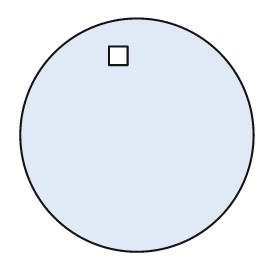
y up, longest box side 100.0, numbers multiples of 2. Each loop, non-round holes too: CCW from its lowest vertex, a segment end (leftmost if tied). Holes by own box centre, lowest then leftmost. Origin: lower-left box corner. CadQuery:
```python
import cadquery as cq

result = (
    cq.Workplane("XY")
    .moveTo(50.0, 50.0)
    .circle(50.0)
    .moveTo(38.0, 80.0)
    .lineTo(46.0, 80.0)
    .lineTo(46.0, 88.0)
    .lineTo(38.0, 88.0)
    .close()
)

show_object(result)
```